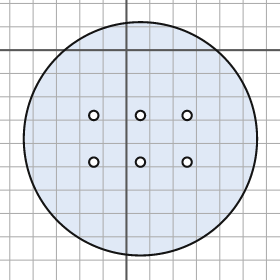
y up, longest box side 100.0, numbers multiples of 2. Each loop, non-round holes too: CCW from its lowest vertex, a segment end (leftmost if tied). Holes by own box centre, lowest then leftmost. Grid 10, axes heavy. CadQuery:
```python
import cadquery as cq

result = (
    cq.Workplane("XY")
    .moveTo(6.0, -38.0)
    .circle(50.0)
    .moveTo(-14.0, -48.0)
    .circle(2.0)
    .moveTo(6.0, -48.0)
    .circle(2.0)
    .moveTo(26.0, -48.0)
    .circle(2.0)
    .moveTo(-14.0, -28.0)
    .circle(2.0)
    .moveTo(6.0, -28.0)
    .circle(2.0)
    .moveTo(26.0, -28.0)
    .circle(2.0)
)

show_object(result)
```